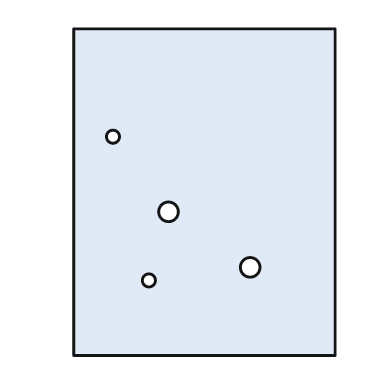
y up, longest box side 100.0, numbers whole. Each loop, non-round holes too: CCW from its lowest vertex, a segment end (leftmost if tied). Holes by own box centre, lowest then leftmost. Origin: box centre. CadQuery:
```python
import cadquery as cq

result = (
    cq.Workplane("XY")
    .moveTo(-40.0, -50.0)
    .lineTo(40.0, -50.0)
    .lineTo(40.0, 50.0)
    .lineTo(-40.0, 50.0)
    .close()
    .moveTo(-17.0, -27.0)
    .circle(2.0)
    .moveTo(14.0, -23.0)
    .circle(3.0)
    .moveTo(-11.0, -6.0)
    .circle(3.0)
    .moveTo(-28.0, 17.0)
    .circle(2.0)
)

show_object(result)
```